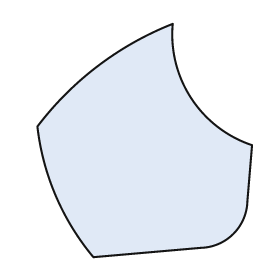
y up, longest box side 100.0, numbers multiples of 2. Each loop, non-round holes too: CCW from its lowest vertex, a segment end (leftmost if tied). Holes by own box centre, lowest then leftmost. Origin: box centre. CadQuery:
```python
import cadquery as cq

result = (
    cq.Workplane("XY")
    .moveTo(-22.0, -50.0)
    .lineTo(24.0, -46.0)
    .threePointArc((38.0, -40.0), (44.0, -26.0))
    .lineTo(46.0, -2.0)
    .threePointArc((20.0, 18.0), (12.0, 50.0))
    .threePointArc((-20.0, 32.0), (-46.0, 6.0))
    .threePointArc((-38.0, -24.0), (-22.0, -50.0))
    .close()
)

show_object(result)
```